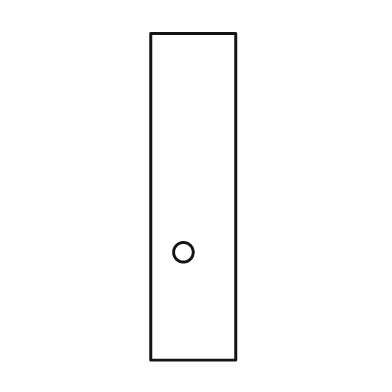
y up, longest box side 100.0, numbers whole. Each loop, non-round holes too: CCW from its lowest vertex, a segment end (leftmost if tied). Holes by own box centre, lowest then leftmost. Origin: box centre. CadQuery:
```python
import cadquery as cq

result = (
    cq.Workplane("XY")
    .moveTo(-13.0, -50.0)
    .lineTo(13.0, -50.0)
    .lineTo(13.0, 50.0)
    .lineTo(-13.0, 50.0)
    .close()
    .moveTo(-3.0, -17.0)
    .circle(3.0)
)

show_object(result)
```